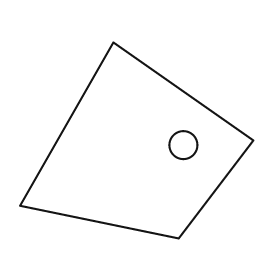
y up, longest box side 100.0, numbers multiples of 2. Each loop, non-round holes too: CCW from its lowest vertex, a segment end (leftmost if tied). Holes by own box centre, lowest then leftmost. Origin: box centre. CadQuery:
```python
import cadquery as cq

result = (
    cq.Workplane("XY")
    .moveTo(18.0, -42.0)
    .lineTo(50.0, 0.0)
    .lineTo(-10.0, 42.0)
    .lineTo(-50.0, -28.0)
    .close()
    .moveTo(20.0, -2.0)
    .circle(6.0)
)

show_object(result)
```